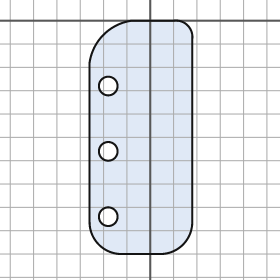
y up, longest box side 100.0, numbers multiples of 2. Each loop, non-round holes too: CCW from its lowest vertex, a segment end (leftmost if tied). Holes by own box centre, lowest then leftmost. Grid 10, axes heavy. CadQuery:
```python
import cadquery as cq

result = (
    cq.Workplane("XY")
    .moveTo(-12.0, -100.0)
    .lineTo(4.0, -100.0)
    .threePointArc((14.0, -96.0), (18.0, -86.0))
    .lineTo(18.0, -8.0)
    .threePointArc((16.0, -2.0), (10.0, 0.0))
    .lineTo(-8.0, 0.0)
    .threePointArc((-20.0, -6.0), (-26.0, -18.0))
    .lineTo(-26.0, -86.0)
    .threePointArc((-22.0, -96.0), (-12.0, -100.0))
    .close()
    .moveTo(-18.0, -84.0)
    .circle(4.0)
    .moveTo(-18.0, -56.0)
    .circle(4.0)
    .moveTo(-18.0, -28.0)
    .circle(4.0)
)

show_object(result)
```